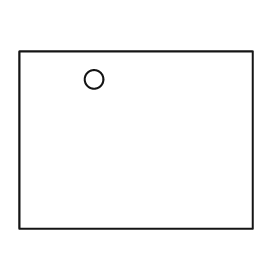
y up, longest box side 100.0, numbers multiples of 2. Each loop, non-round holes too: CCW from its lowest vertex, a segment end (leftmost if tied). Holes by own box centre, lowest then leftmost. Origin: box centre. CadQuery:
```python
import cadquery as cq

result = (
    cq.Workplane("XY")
    .moveTo(-50.0, -38.0)
    .lineTo(50.0, -38.0)
    .lineTo(50.0, 38.0)
    .lineTo(-50.0, 38.0)
    .close()
    .moveTo(-18.0, 26.0)
    .circle(4.0)
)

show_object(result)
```